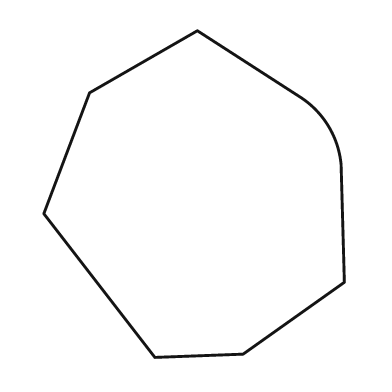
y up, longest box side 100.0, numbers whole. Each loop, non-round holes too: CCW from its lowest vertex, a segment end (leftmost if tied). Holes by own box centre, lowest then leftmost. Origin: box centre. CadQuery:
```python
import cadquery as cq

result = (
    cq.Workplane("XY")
    .moveTo(-12.0, -50.0)
    .lineTo(15.0, -49.0)
    .lineTo(46.0, -27.0)
    .lineTo(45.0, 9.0)
    .threePointArc((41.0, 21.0), (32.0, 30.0))
    .lineTo(1.0, 50.0)
    .lineTo(-32.0, 31.0)
    .lineTo(-46.0, -6.0)
    .close()
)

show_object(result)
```